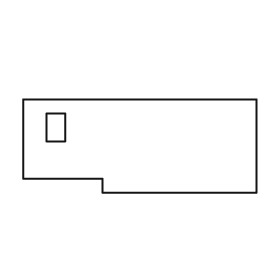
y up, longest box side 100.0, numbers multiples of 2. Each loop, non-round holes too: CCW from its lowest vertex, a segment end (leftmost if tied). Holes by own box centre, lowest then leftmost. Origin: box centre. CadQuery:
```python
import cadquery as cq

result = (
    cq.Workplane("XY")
    .moveTo(-16.0, -20.0)
    .lineTo(50.0, -20.0)
    .lineTo(50.0, 20.0)
    .lineTo(-50.0, 20.0)
    .lineTo(-50.0, -14.0)
    .lineTo(-16.0, -14.0)
    .close()
    .moveTo(-40.0, 2.0)
    .lineTo(-32.0, 2.0)
    .lineTo(-32.0, 14.0)
    .lineTo(-40.0, 14.0)
    .close()
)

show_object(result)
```